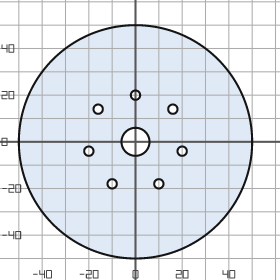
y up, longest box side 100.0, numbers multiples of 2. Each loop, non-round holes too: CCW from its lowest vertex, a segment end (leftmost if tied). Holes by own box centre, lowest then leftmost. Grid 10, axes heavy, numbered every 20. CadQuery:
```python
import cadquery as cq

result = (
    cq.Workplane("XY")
    .moveTo(0.0, 0.0)
    .circle(50.0)
    .moveTo(-10.0, -18.0)
    .circle(2.0)
    .moveTo(10.0, -18.0)
    .circle(2.0)
    .moveTo(-20.0, -4.0)
    .circle(2.0)
    .moveTo(20.0, -4.0)
    .circle(2.0)
    .moveTo(0.0, 0.0)
    .circle(6.0)
    .moveTo(-16.0, 14.0)
    .circle(2.0)
    .moveTo(16.0, 14.0)
    .circle(2.0)
    .moveTo(0.0, 20.0)
    .circle(2.0)
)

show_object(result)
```